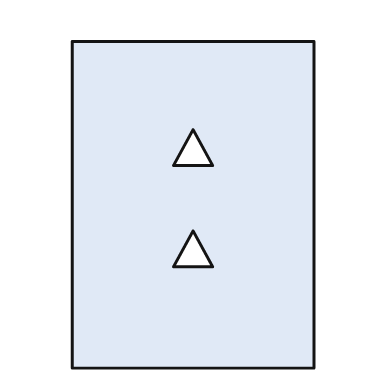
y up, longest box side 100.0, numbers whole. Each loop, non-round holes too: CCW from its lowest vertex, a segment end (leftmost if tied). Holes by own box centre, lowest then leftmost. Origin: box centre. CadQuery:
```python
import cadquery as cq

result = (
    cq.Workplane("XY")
    .moveTo(-37.0, -50.0)
    .lineTo(37.0, -50.0)
    .lineTo(37.0, 50.0)
    .lineTo(-37.0, 50.0)
    .close()
    .moveTo(-6.0, -19.0)
    .lineTo(6.0, -19.0)
    .lineTo(0.0, -8.0)
    .close()
    .moveTo(-6.0, 12.0)
    .lineTo(6.0, 12.0)
    .lineTo(0.0, 23.0)
    .close()
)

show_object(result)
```